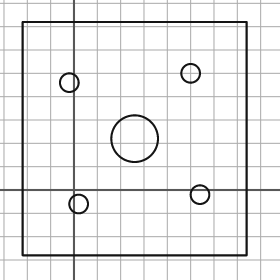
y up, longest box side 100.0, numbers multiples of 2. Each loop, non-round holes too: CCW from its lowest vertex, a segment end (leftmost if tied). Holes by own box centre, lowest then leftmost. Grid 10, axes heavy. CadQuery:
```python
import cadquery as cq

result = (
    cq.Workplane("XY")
    .moveTo(-22.0, -28.0)
    .lineTo(74.0, -28.0)
    .lineTo(74.0, 72.0)
    .lineTo(-22.0, 72.0)
    .close()
    .moveTo(2.0, -6.0)
    .circle(4.0)
    .moveTo(54.0, -2.0)
    .circle(4.0)
    .moveTo(26.0, 22.0)
    .circle(10.0)
    .moveTo(-2.0, 46.0)
    .circle(4.0)
    .moveTo(50.0, 50.0)
    .circle(4.0)
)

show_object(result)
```